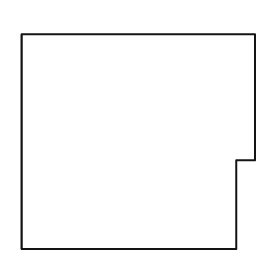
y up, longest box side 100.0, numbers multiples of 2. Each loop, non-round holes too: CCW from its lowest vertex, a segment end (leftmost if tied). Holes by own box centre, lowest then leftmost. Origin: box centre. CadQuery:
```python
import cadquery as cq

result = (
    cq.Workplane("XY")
    .moveTo(-50.0, -46.0)
    .lineTo(42.0, -46.0)
    .lineTo(42.0, -8.0)
    .lineTo(50.0, -8.0)
    .lineTo(50.0, 46.0)
    .lineTo(-50.0, 46.0)
    .close()
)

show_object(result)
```